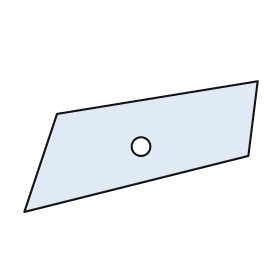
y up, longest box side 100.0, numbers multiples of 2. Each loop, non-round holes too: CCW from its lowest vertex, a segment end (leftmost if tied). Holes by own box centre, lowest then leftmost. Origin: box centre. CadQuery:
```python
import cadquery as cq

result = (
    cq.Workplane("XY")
    .moveTo(-50.0, -28.0)
    .lineTo(46.0, -4.0)
    .lineTo(50.0, 28.0)
    .lineTo(-36.0, 14.0)
    .close()
    .moveTo(0.0, 0.0)
    .circle(4.0)
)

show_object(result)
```